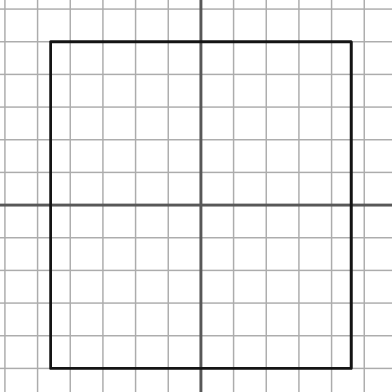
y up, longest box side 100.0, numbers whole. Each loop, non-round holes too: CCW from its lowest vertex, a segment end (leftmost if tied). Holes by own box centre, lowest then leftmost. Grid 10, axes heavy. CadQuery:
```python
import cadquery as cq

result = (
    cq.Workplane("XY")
    .moveTo(-46.0, -50.0)
    .lineTo(46.0, -50.0)
    .lineTo(46.0, 50.0)
    .lineTo(-46.0, 50.0)
    .close()
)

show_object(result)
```